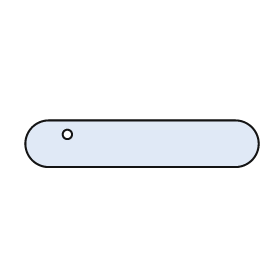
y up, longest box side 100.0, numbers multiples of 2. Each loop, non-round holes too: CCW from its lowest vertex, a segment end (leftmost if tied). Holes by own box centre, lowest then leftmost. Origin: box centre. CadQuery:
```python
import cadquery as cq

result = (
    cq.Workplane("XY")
    .moveTo(-40.0, -10.0)
    .lineTo(40.0, -10.0)
    .threePointArc((50.0, 0.0), (40.0, 10.0))
    .lineTo(-40.0, 10.0)
    .threePointArc((-50.0, 0.0), (-40.0, -10.0))
    .close()
    .moveTo(-32.0, 4.0)
    .circle(2.0)
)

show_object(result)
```